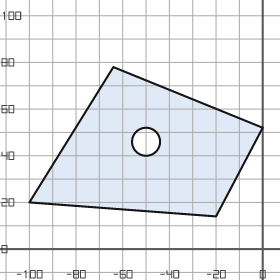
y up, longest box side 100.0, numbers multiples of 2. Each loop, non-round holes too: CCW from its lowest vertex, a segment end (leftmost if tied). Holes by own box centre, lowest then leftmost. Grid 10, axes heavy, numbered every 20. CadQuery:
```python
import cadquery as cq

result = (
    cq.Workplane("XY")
    .moveTo(-20.0, 14.0)
    .lineTo(0.0, 52.0)
    .lineTo(-64.0, 78.0)
    .lineTo(-100.0, 20.0)
    .close()
    .moveTo(-50.0, 46.0)
    .circle(6.0)
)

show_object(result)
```